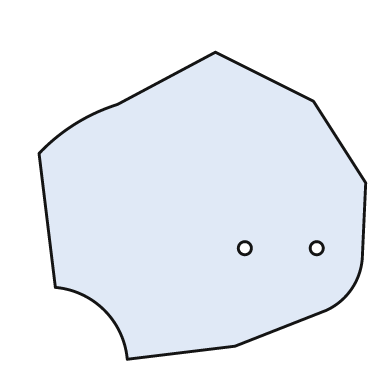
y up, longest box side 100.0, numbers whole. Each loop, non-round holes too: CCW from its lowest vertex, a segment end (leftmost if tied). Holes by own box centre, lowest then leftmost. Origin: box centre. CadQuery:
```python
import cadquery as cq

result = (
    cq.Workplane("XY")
    .moveTo(-23.0, -47.0)
    .lineTo(10.0, -43.0)
    .lineTo(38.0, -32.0)
    .threePointArc((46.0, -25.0), (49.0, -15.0))
    .lineTo(50.0, 7.0)
    .lineTo(34.0, 32.0)
    .lineTo(4.0, 47.0)
    .lineTo(-26.0, 31.0)
    .threePointArc((-39.0, 25.0), (-50.0, 16.0))
    .lineTo(-45.0, -25.0)
    .threePointArc((-30.0, -32.0), (-23.0, -47.0))
    .close()
    .moveTo(13.0, -13.0)
    .circle(2.0)
    .moveTo(35.0, -13.0)
    .circle(2.0)
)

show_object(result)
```